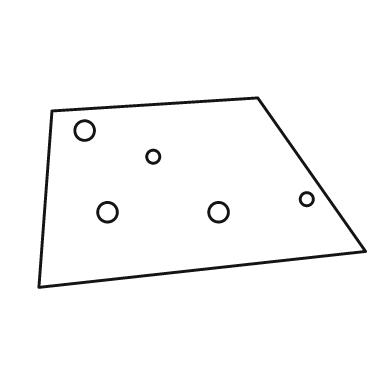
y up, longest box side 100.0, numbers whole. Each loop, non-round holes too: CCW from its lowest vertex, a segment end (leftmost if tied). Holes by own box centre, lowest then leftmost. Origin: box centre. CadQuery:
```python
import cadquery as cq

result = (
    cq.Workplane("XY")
    .moveTo(-50.0, -29.0)
    .lineTo(50.0, -18.0)
    .lineTo(17.0, 29.0)
    .lineTo(-46.0, 25.0)
    .close()
    .moveTo(-29.0, -6.0)
    .circle(3.0)
    .moveTo(5.0, -6.0)
    .circle(3.0)
    .moveTo(32.0, -2.0)
    .circle(2.0)
    .moveTo(-15.0, 11.0)
    .circle(2.0)
    .moveTo(-36.0, 19.0)
    .circle(3.0)
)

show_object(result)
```